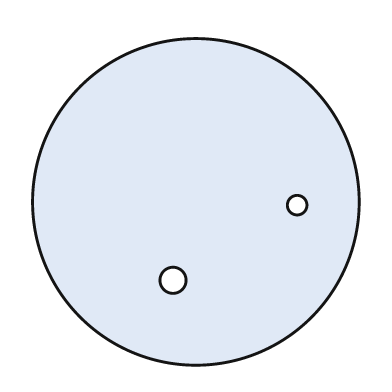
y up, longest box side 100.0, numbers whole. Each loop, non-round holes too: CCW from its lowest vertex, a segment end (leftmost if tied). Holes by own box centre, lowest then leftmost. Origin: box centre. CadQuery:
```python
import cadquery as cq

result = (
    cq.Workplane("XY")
    .moveTo(0.0, 0.0)
    .circle(50.0)
    .moveTo(-7.0, -24.0)
    .circle(4.0)
    .moveTo(31.0, -1.0)
    .circle(3.0)
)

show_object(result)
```